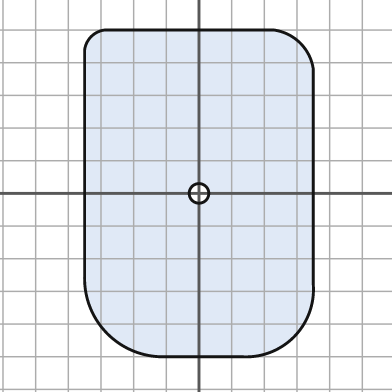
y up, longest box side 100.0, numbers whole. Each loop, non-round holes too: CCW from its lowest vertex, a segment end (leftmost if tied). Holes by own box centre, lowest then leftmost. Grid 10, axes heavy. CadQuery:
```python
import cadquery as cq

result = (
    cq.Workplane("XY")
    .moveTo(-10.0, -50.0)
    .lineTo(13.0, -50.0)
    .threePointArc((29.0, -44.0), (35.0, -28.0))
    .lineTo(35.0, 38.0)
    .threePointArc((31.0, 46.0), (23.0, 50.0))
    .lineTo(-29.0, 50.0)
    .threePointArc((-33.0, 48.0), (-35.0, 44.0))
    .lineTo(-35.0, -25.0)
    .threePointArc((-28.0, -43.0), (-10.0, -50.0))
    .close()
    .moveTo(0.0, 0.0)
    .circle(3.0)
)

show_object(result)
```